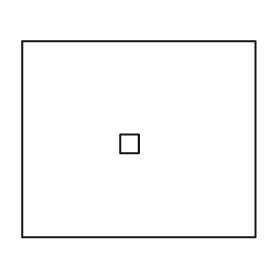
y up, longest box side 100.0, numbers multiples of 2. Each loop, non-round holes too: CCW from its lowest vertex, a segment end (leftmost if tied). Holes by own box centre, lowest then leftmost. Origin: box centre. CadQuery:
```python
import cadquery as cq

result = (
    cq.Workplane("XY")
    .moveTo(-50.0, -42.0)
    .lineTo(50.0, -42.0)
    .lineTo(50.0, 42.0)
    .lineTo(-50.0, 42.0)
    .close()
    .moveTo(-8.0, -6.0)
    .lineTo(0.0, -6.0)
    .lineTo(0.0, 2.0)
    .lineTo(-8.0, 2.0)
    .close()
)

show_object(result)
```